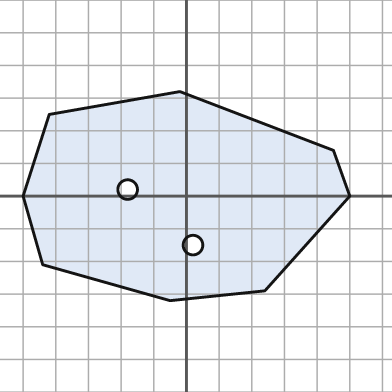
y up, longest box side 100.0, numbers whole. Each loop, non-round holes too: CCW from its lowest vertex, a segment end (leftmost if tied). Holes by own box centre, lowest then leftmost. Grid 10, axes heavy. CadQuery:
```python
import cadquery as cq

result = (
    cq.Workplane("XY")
    .moveTo(-5.0, -32.0)
    .lineTo(24.0, -29.0)
    .lineTo(50.0, 0.0)
    .lineTo(45.0, 14.0)
    .lineTo(-2.0, 32.0)
    .lineTo(-42.0, 25.0)
    .lineTo(-50.0, 0.0)
    .lineTo(-44.0, -21.0)
    .close()
    .moveTo(2.0, -15.0)
    .circle(3.0)
    .moveTo(-18.0, 2.0)
    .circle(3.0)
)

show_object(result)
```